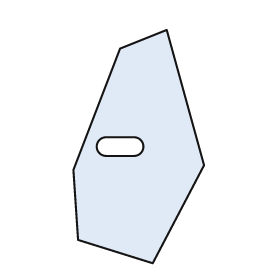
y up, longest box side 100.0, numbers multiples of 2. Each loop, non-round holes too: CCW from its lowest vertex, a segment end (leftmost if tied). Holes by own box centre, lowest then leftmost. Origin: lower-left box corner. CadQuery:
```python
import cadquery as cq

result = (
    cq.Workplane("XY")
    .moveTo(34.0, 0.0)
    .lineTo(56.0, 42.0)
    .lineTo(40.0, 100.0)
    .lineTo(20.0, 92.0)
    .lineTo(0.0, 40.0)
    .lineTo(2.0, 10.0)
    .close()
    .moveTo(14.0, 46.0)
    .lineTo(26.0, 46.0)
    .threePointArc((30.0, 50.0), (26.0, 54.0))
    .lineTo(14.0, 54.0)
    .threePointArc((10.0, 50.0), (14.0, 46.0))
    .close()
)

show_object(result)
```